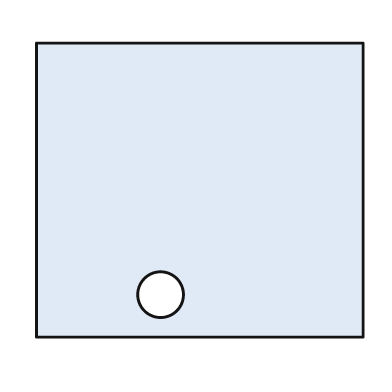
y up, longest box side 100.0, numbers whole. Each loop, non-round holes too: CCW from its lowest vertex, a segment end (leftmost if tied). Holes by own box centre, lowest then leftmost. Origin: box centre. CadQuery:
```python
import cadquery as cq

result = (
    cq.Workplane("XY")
    .moveTo(-50.0, -45.0)
    .lineTo(50.0, -45.0)
    .lineTo(50.0, 45.0)
    .lineTo(-50.0, 45.0)
    .close()
    .moveTo(-12.0, -32.0)
    .circle(7.0)
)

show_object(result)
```